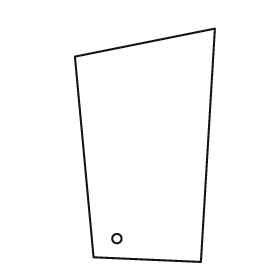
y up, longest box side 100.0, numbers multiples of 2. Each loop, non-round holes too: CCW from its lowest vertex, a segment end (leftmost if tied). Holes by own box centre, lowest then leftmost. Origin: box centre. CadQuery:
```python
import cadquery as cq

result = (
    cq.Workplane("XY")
    .moveTo(24.0, -50.0)
    .lineTo(30.0, 50.0)
    .lineTo(-30.0, 38.0)
    .lineTo(-22.0, -48.0)
    .close()
    .moveTo(-12.0, -40.0)
    .circle(2.0)
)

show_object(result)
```